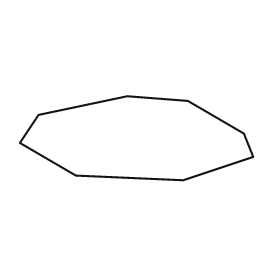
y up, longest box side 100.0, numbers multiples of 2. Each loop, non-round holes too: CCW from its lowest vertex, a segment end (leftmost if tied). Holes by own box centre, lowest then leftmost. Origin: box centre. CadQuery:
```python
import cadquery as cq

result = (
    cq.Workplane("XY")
    .moveTo(20.0, -18.0)
    .lineTo(50.0, -8.0)
    .lineTo(46.0, 2.0)
    .lineTo(22.0, 16.0)
    .lineTo(-4.0, 18.0)
    .lineTo(-42.0, 10.0)
    .lineTo(-50.0, -2.0)
    .lineTo(-26.0, -16.0)
    .close()
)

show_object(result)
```